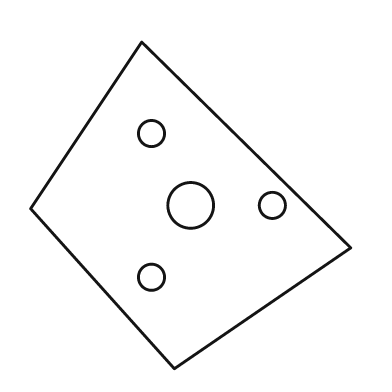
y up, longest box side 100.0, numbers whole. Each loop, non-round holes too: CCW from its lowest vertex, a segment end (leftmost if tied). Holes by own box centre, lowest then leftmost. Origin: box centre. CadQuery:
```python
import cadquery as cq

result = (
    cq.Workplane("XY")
    .moveTo(-5.0, -50.0)
    .lineTo(49.0, -13.0)
    .lineTo(-15.0, 50.0)
    .lineTo(-49.0, -1.0)
    .close()
    .moveTo(-12.0, -22.0)
    .circle(4.0)
    .moveTo(0.0, 0.0)
    .circle(7.0)
    .moveTo(25.0, 0.0)
    .circle(4.0)
    .moveTo(-12.0, 22.0)
    .circle(4.0)
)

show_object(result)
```